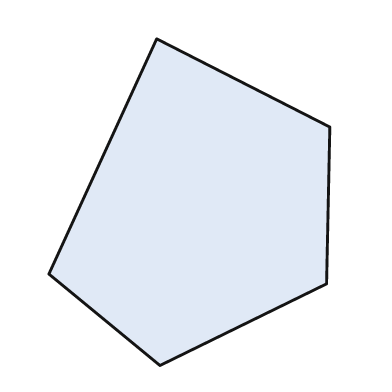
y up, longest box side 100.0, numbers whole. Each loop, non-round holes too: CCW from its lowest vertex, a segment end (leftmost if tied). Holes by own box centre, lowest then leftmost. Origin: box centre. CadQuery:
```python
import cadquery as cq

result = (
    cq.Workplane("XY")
    .moveTo(-9.0, -50.0)
    .lineTo(42.0, -25.0)
    .lineTo(43.0, 23.0)
    .lineTo(-10.0, 50.0)
    .lineTo(-43.0, -22.0)
    .close()
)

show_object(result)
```